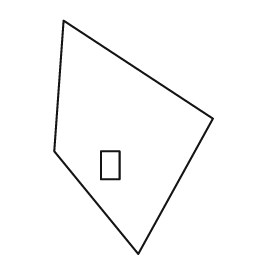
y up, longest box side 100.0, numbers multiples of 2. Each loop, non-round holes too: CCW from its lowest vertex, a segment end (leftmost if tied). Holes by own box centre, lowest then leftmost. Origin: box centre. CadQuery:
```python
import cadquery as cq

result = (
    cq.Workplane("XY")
    .moveTo(2.0, -50.0)
    .lineTo(34.0, 8.0)
    .lineTo(-30.0, 50.0)
    .lineTo(-34.0, -6.0)
    .close()
    .moveTo(-14.0, -18.0)
    .lineTo(-6.0, -18.0)
    .lineTo(-6.0, -6.0)
    .lineTo(-14.0, -6.0)
    .close()
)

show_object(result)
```